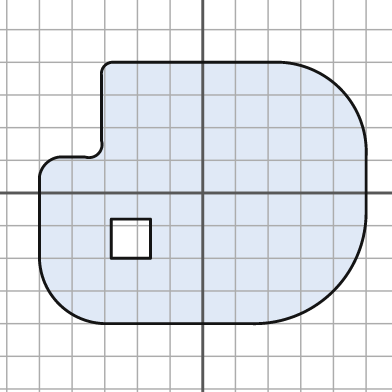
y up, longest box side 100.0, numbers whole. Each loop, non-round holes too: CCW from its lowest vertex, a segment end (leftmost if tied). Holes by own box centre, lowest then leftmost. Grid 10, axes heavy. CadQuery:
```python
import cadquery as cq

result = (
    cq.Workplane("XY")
    .moveTo(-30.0, -40.0)
    .lineTo(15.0, -40.0)
    .threePointArc((40.0, -30.0), (50.0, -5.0))
    .lineTo(50.0, 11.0)
    .threePointArc((42.0, 32.0), (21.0, 40.0))
    .lineTo(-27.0, 40.0)
    .threePointArc((-30.0, 39.0), (-31.0, 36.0))
    .lineTo(-31.0, 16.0)
    .threePointArc((-32.0, 12.0), (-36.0, 11.0))
    .lineTo(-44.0, 11.0)
    .threePointArc((-48.0, 9.0), (-50.0, 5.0))
    .lineTo(-50.0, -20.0)
    .threePointArc((-44.0, -34.0), (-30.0, -40.0))
    .close()
    .moveTo(-28.0, -20.0)
    .lineTo(-16.0, -20.0)
    .lineTo(-16.0, -8.0)
    .lineTo(-28.0, -8.0)
    .close()
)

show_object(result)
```